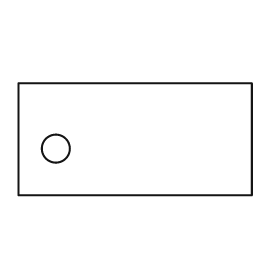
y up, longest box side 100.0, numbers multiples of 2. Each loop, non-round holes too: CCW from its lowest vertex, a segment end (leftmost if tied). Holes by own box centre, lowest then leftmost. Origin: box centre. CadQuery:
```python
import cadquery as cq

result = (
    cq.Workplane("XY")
    .moveTo(-50.0, -24.0)
    .lineTo(50.0, -24.0)
    .lineTo(50.0, 24.0)
    .lineTo(-50.0, 24.0)
    .close()
    .moveTo(-34.0, -4.0)
    .circle(6.0)
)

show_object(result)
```